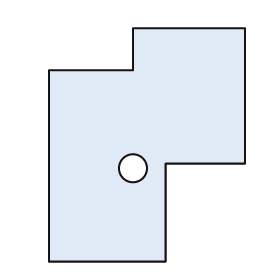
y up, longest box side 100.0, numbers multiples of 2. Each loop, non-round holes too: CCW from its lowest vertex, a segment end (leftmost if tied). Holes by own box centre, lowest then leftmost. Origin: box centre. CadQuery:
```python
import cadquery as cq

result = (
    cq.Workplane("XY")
    .moveTo(-42.0, -50.0)
    .lineTo(8.0, -50.0)
    .lineTo(8.0, -8.0)
    .lineTo(42.0, -8.0)
    .lineTo(42.0, 50.0)
    .lineTo(-6.0, 50.0)
    .lineTo(-6.0, 32.0)
    .lineTo(-42.0, 32.0)
    .close()
    .moveTo(-6.0, -10.0)
    .circle(6.0)
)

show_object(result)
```